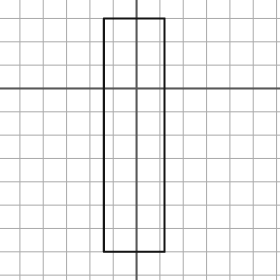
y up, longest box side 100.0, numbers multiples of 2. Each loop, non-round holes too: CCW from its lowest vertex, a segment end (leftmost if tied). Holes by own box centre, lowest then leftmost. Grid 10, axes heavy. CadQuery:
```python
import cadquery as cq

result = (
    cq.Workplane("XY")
    .moveTo(-14.0, -70.0)
    .lineTo(12.0, -70.0)
    .lineTo(12.0, 30.0)
    .lineTo(-14.0, 30.0)
    .close()
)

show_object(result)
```